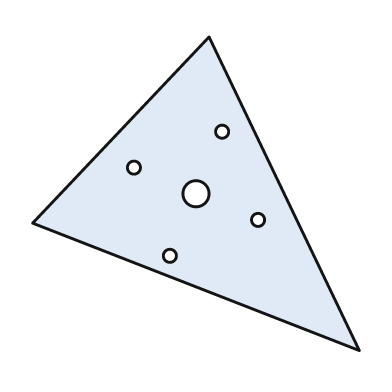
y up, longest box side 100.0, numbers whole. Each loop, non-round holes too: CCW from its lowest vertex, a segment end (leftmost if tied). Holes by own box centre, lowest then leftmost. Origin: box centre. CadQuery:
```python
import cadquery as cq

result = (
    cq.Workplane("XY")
    .moveTo(50.0, -48.0)
    .lineTo(4.0, 48.0)
    .lineTo(-50.0, -9.0)
    .close()
    .moveTo(-8.0, -19.0)
    .circle(2.0)
    .moveTo(19.0, -8.0)
    .circle(2.0)
    .moveTo(0.0, 0.0)
    .circle(4.0)
    .moveTo(-19.0, 8.0)
    .circle(2.0)
    .moveTo(8.0, 19.0)
    .circle(2.0)
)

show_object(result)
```